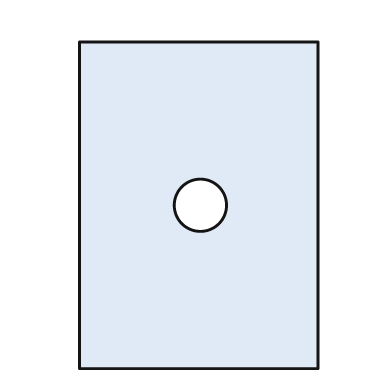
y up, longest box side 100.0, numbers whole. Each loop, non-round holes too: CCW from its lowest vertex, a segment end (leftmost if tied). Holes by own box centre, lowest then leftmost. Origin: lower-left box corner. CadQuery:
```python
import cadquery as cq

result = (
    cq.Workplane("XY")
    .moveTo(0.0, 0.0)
    .lineTo(73.0, 0.0)
    .lineTo(73.0, 100.0)
    .lineTo(0.0, 100.0)
    .close()
    .moveTo(37.0, 50.0)
    .circle(8.0)
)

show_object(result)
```